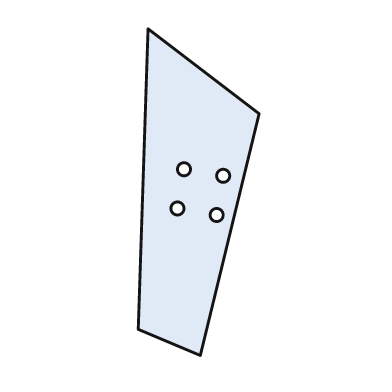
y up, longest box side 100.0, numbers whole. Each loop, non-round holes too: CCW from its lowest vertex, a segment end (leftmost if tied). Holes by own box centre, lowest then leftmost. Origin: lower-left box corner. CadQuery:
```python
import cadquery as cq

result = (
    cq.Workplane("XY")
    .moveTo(19.0, 0.0)
    .lineTo(37.0, 74.0)
    .lineTo(3.0, 100.0)
    .lineTo(0.0, 8.0)
    .close()
    .moveTo(24.0, 43.0)
    .circle(2.0)
    .moveTo(12.0, 45.0)
    .circle(2.0)
    .moveTo(26.0, 55.0)
    .circle(2.0)
    .moveTo(14.0, 57.0)
    .circle(2.0)
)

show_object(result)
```